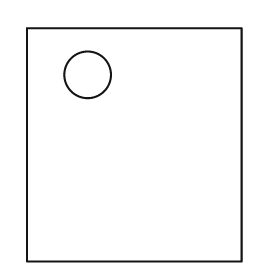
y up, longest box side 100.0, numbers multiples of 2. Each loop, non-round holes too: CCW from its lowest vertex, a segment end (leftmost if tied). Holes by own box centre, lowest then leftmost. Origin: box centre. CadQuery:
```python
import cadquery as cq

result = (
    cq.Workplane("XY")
    .moveTo(-46.0, -50.0)
    .lineTo(46.0, -50.0)
    .lineTo(46.0, 50.0)
    .lineTo(-46.0, 50.0)
    .close()
    .moveTo(-20.0, 30.0)
    .circle(10.0)
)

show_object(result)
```